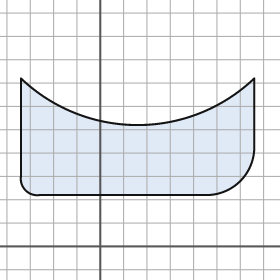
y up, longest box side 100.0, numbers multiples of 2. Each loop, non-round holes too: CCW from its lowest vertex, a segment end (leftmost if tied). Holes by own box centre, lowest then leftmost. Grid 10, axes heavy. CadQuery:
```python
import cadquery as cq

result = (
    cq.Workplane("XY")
    .moveTo(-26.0, 22.0)
    .lineTo(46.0, 22.0)
    .threePointArc((60.0, 28.0), (66.0, 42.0))
    .lineTo(66.0, 72.0)
    .threePointArc((16.0, 52.0), (-34.0, 72.0))
    .lineTo(-34.0, 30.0)
    .threePointArc((-32.0, 24.0), (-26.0, 22.0))
    .close()
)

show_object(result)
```